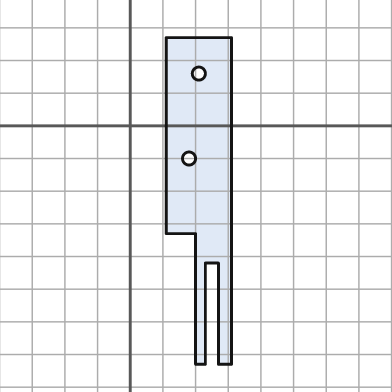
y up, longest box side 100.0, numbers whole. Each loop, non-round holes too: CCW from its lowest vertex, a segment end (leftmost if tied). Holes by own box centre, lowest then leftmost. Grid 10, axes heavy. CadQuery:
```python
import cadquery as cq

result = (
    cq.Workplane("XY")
    .moveTo(20.0, -73.0)
    .lineTo(23.0, -73.0)
    .lineTo(23.0, -42.0)
    .lineTo(27.0, -42.0)
    .lineTo(27.0, -73.0)
    .lineTo(31.0, -73.0)
    .lineTo(31.0, 27.0)
    .lineTo(11.0, 27.0)
    .lineTo(11.0, -33.0)
    .lineTo(20.0, -33.0)
    .close()
    .moveTo(18.0, -10.0)
    .circle(2.0)
    .moveTo(21.0, 16.0)
    .circle(2.0)
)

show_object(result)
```